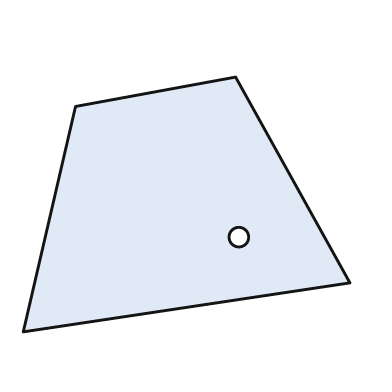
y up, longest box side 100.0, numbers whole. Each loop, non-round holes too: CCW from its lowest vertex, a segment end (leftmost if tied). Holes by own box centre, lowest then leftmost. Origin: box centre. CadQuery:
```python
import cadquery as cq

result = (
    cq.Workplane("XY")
    .moveTo(-50.0, -39.0)
    .lineTo(50.0, -24.0)
    .lineTo(15.0, 39.0)
    .lineTo(-34.0, 30.0)
    .close()
    .moveTo(16.0, -10.0)
    .circle(3.0)
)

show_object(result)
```